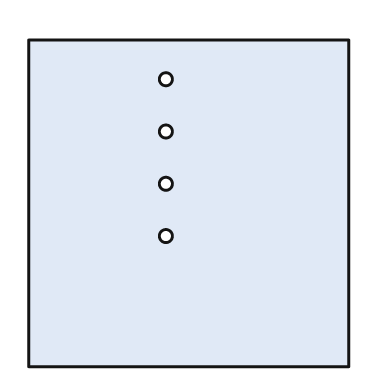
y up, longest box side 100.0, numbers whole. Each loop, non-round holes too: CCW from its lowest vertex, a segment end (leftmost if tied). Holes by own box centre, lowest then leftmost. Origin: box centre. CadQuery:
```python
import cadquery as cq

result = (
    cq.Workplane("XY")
    .moveTo(-49.0, -50.0)
    .lineTo(49.0, -50.0)
    .lineTo(49.0, 50.0)
    .lineTo(-49.0, 50.0)
    .close()
    .moveTo(-7.0, -10.0)
    .circle(2.0)
    .moveTo(-7.0, 6.0)
    .circle(2.0)
    .moveTo(-7.0, 22.0)
    .circle(2.0)
    .moveTo(-7.0, 38.0)
    .circle(2.0)
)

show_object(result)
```